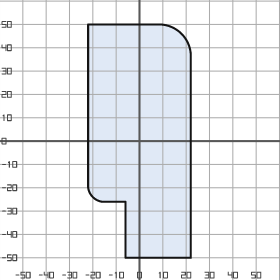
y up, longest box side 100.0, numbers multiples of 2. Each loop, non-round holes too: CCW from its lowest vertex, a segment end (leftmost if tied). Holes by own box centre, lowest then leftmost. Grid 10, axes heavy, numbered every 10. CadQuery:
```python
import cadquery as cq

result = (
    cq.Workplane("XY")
    .moveTo(-6.0, -50.0)
    .lineTo(22.0, -50.0)
    .lineTo(22.0, 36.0)
    .threePointArc((18.0, 46.0), (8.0, 50.0))
    .lineTo(-22.0, 50.0)
    .lineTo(-22.0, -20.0)
    .threePointArc((-20.0, -24.0), (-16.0, -26.0))
    .lineTo(-6.0, -26.0)
    .close()
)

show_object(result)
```